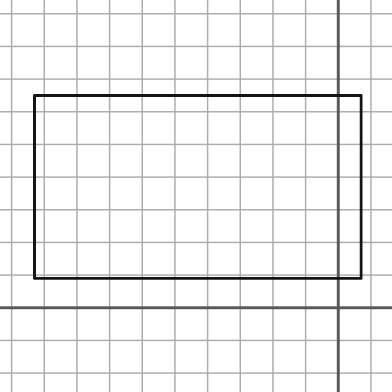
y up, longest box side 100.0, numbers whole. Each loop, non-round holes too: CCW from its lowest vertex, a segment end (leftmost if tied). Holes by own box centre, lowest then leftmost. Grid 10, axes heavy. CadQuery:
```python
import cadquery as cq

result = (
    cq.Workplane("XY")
    .moveTo(-93.0, 9.0)
    .lineTo(7.0, 9.0)
    .lineTo(7.0, 65.0)
    .lineTo(-93.0, 65.0)
    .close()
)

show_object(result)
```